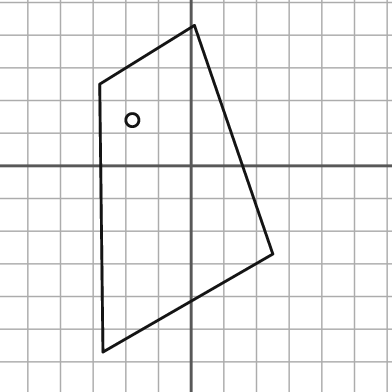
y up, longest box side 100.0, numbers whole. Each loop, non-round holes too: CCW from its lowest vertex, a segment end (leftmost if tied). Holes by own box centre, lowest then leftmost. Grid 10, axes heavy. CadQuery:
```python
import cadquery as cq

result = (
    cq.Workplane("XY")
    .moveTo(-27.0, -57.0)
    .lineTo(25.0, -27.0)
    .lineTo(1.0, 43.0)
    .lineTo(-28.0, 25.0)
    .close()
    .moveTo(-18.0, 14.0)
    .circle(2.0)
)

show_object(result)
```